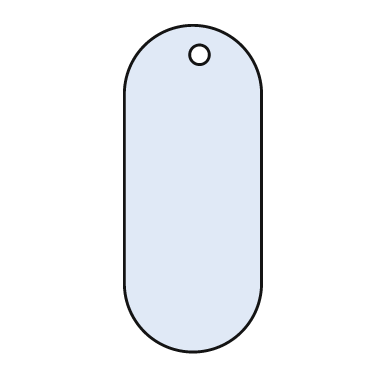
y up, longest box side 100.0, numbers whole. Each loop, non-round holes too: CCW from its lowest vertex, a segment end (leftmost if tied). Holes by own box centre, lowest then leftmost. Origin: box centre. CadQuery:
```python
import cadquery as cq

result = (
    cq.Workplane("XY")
    .moveTo(-21.0, -29.0)
    .threePointArc((0.0, -50.0), (21.0, -29.0))
    .lineTo(21.0, 29.0)
    .threePointArc((0.0, 50.0), (-21.0, 29.0))
    .close()
    .moveTo(2.0, 41.0)
    .circle(3.0)
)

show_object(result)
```